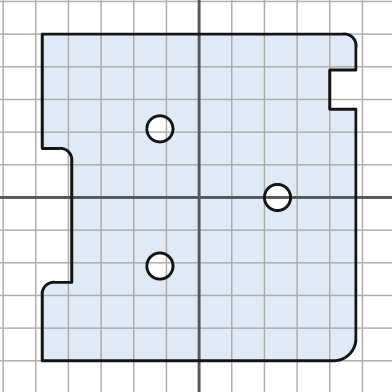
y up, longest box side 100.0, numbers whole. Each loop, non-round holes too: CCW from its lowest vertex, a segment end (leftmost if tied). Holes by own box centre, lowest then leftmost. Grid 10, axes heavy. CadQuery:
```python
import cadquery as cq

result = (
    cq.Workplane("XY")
    .moveTo(-48.0, -50.0)
    .lineTo(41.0, -50.0)
    .threePointArc((46.0, -48.0), (48.0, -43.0))
    .lineTo(48.0, 27.0)
    .lineTo(40.0, 27.0)
    .lineTo(40.0, 39.0)
    .lineTo(48.0, 39.0)
    .lineTo(48.0, 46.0)
    .threePointArc((47.0, 49.0), (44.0, 50.0))
    .lineTo(-48.0, 50.0)
    .lineTo(-48.0, 15.0)
    .lineTo(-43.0, 15.0)
    .threePointArc((-40.0, 14.0), (-39.0, 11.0))
    .lineTo(-39.0, -26.0)
    .lineTo(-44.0, -26.0)
    .threePointArc((-47.0, -27.0), (-48.0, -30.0))
    .close()
    .moveTo(-12.0, -21.0)
    .circle(4.0)
    .moveTo(24.0, 0.0)
    .circle(4.0)
    .moveTo(-12.0, 21.0)
    .circle(4.0)
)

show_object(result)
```